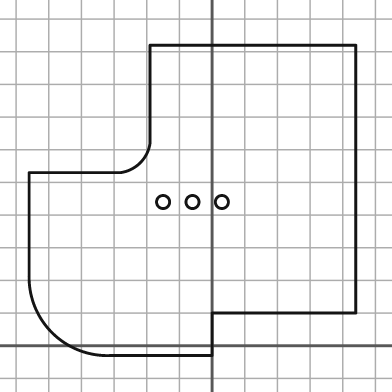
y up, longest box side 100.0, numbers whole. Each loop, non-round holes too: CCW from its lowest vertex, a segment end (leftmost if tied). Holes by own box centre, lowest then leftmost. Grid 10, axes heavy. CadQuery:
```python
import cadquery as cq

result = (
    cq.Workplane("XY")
    .moveTo(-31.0, -3.0)
    .lineTo(0.0, -3.0)
    .lineTo(0.0, 10.0)
    .lineTo(44.0, 10.0)
    .lineTo(44.0, 92.0)
    .lineTo(-19.0, 92.0)
    .lineTo(-19.0, 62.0)
    .threePointArc((-22.0, 56.0), (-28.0, 53.0))
    .lineTo(-56.0, 53.0)
    .lineTo(-56.0, 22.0)
    .threePointArc((-49.0, 4.0), (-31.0, -3.0))
    .close()
    .moveTo(-15.0, 44.0)
    .circle(2.0)
    .moveTo(-6.0, 44.0)
    .circle(2.0)
    .moveTo(3.0, 44.0)
    .circle(2.0)
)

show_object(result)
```